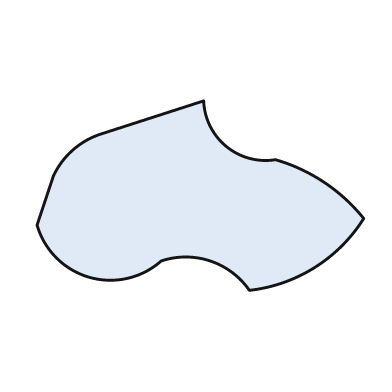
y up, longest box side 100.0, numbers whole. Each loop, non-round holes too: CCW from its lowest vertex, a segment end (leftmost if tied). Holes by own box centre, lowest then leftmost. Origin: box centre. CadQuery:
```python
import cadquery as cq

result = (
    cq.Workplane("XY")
    .moveTo(15.0, -29.0)
    .threePointArc((35.0, -22.0), (50.0, -7.0))
    .threePointArc((38.0, 4.0), (23.0, 11.0))
    .threePointArc((8.0, 15.0), (1.0, 29.0))
    .lineTo(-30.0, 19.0)
    .threePointArc((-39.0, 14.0), (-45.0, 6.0))
    .lineTo(-50.0, -9.0)
    .threePointArc((-34.0, -25.0), (-12.0, -20.0))
    .threePointArc((3.0, -20.0), (15.0, -29.0))
    .close()
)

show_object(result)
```